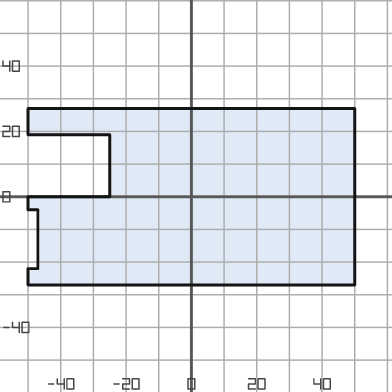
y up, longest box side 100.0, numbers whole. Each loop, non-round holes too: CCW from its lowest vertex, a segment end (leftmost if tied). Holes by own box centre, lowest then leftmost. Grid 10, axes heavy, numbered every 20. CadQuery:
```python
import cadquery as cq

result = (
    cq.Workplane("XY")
    .moveTo(-50.0, -27.0)
    .lineTo(50.0, -27.0)
    .lineTo(50.0, 27.0)
    .lineTo(-50.0, 27.0)
    .lineTo(-50.0, 19.0)
    .lineTo(-25.0, 19.0)
    .lineTo(-25.0, 0.0)
    .lineTo(-50.0, 0.0)
    .lineTo(-50.0, -4.0)
    .lineTo(-47.0, -4.0)
    .lineTo(-47.0, -22.0)
    .lineTo(-50.0, -22.0)
    .close()
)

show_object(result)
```